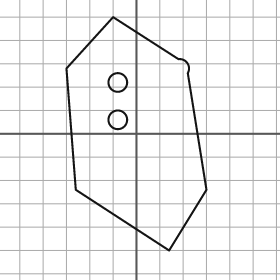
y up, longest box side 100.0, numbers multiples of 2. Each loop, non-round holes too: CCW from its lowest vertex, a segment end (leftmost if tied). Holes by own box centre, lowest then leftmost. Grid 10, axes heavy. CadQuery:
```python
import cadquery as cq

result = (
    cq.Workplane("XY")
    .moveTo(14.0, -50.0)
    .lineTo(30.0, -24.0)
    .lineTo(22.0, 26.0)
    .threePointArc((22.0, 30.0), (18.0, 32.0))
    .lineTo(-10.0, 50.0)
    .lineTo(-30.0, 28.0)
    .lineTo(-26.0, -24.0)
    .close()
    .moveTo(-8.0, 6.0)
    .circle(4.0)
    .moveTo(-8.0, 22.0)
    .circle(4.0)
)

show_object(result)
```